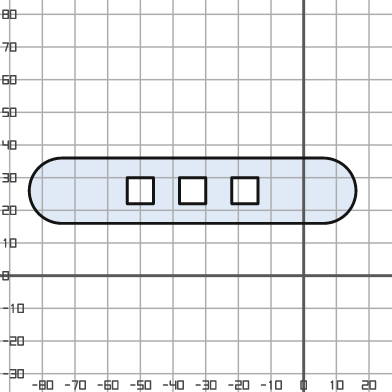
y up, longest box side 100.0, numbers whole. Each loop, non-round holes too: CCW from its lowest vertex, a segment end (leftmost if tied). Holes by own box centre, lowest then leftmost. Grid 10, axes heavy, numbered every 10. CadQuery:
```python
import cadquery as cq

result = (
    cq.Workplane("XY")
    .moveTo(-74.0, 16.0)
    .lineTo(6.0, 16.0)
    .threePointArc((16.0, 26.0), (6.0, 36.0))
    .lineTo(-74.0, 36.0)
    .threePointArc((-84.0, 26.0), (-74.0, 16.0))
    .close()
    .moveTo(-54.0, 22.0)
    .lineTo(-46.0, 22.0)
    .lineTo(-46.0, 30.0)
    .lineTo(-54.0, 30.0)
    .close()
    .moveTo(-38.0, 22.0)
    .lineTo(-30.0, 22.0)
    .lineTo(-30.0, 30.0)
    .lineTo(-38.0, 30.0)
    .close()
    .moveTo(-22.0, 22.0)
    .lineTo(-14.0, 22.0)
    .lineTo(-14.0, 30.0)
    .lineTo(-22.0, 30.0)
    .close()
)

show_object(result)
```